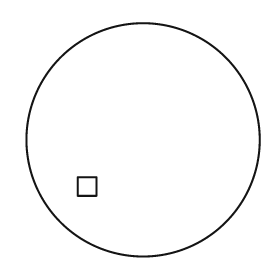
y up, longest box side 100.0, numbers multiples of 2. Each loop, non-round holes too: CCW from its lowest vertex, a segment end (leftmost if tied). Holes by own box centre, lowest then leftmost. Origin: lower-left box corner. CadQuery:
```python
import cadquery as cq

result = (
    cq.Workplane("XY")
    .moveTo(50.0, 50.0)
    .circle(50.0)
    .moveTo(22.0, 26.0)
    .lineTo(30.0, 26.0)
    .lineTo(30.0, 34.0)
    .lineTo(22.0, 34.0)
    .close()
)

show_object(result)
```